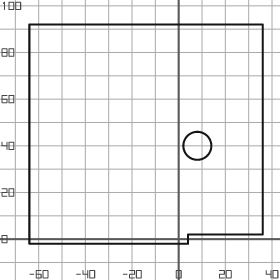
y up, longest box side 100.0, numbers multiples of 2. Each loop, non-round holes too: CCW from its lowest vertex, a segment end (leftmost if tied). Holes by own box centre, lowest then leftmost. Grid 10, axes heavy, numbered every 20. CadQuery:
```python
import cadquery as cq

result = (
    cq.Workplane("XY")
    .moveTo(-64.0, -2.0)
    .lineTo(4.0, -2.0)
    .lineTo(4.0, 2.0)
    .lineTo(36.0, 2.0)
    .lineTo(36.0, 92.0)
    .lineTo(-64.0, 92.0)
    .close()
    .moveTo(8.0, 40.0)
    .circle(6.0)
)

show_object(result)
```